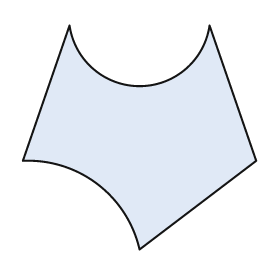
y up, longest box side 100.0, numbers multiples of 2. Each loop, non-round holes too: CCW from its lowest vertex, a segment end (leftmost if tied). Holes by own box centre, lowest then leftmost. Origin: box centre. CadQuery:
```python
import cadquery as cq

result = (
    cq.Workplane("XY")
    .moveTo(0.0, -48.0)
    .lineTo(50.0, -10.0)
    .lineTo(30.0, 48.0)
    .threePointArc((0.0, 22.0), (-30.0, 48.0))
    .lineTo(-50.0, -10.0)
    .threePointArc((-18.0, -20.0), (0.0, -48.0))
    .close()
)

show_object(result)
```